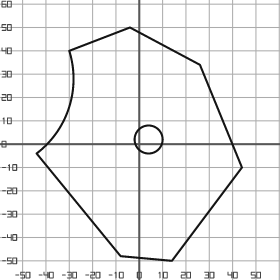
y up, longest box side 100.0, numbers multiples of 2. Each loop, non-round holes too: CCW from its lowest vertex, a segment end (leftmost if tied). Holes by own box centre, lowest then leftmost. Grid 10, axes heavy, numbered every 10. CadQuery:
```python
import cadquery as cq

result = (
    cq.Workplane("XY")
    .moveTo(14.0, -50.0)
    .lineTo(44.0, -10.0)
    .lineTo(26.0, 34.0)
    .lineTo(-4.0, 50.0)
    .lineTo(-30.0, 40.0)
    .threePointArc((-30.0, 16.0), (-44.0, -4.0))
    .lineTo(-8.0, -48.0)
    .close()
    .moveTo(4.0, 2.0)
    .circle(6.0)
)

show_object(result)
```